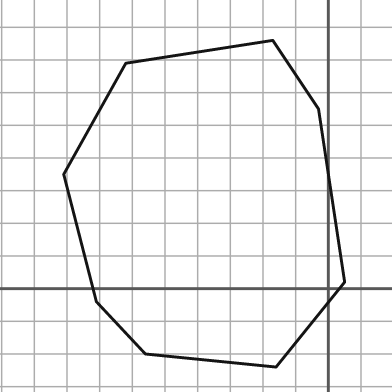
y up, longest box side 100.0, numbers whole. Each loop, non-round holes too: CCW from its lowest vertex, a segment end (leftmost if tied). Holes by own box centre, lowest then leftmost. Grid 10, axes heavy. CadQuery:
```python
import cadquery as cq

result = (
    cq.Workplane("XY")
    .moveTo(-16.0, -24.0)
    .lineTo(5.0, 2.0)
    .lineTo(-3.0, 55.0)
    .lineTo(-17.0, 76.0)
    .lineTo(-62.0, 69.0)
    .lineTo(-81.0, 35.0)
    .lineTo(-71.0, -4.0)
    .lineTo(-56.0, -20.0)
    .close()
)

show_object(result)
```